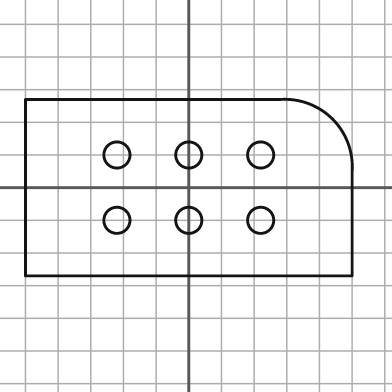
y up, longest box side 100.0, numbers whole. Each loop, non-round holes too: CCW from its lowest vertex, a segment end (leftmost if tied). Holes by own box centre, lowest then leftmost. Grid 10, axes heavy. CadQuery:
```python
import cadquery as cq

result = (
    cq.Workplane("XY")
    .moveTo(-50.0, -27.0)
    .lineTo(50.0, -27.0)
    .lineTo(50.0, 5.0)
    .threePointArc((44.0, 21.0), (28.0, 27.0))
    .lineTo(-50.0, 27.0)
    .close()
    .moveTo(-22.0, -10.0)
    .circle(4.0)
    .moveTo(0.0, -10.0)
    .circle(4.0)
    .moveTo(22.0, -10.0)
    .circle(4.0)
    .moveTo(-22.0, 10.0)
    .circle(4.0)
    .moveTo(0.0, 10.0)
    .circle(4.0)
    .moveTo(22.0, 10.0)
    .circle(4.0)
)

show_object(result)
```